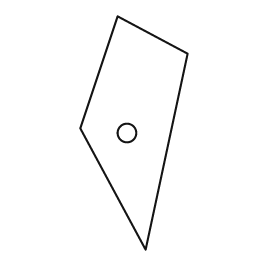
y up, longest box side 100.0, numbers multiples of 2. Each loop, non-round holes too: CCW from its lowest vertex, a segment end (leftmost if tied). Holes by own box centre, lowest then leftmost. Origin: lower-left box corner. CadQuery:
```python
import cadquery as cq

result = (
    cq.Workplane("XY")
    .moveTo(28.0, 0.0)
    .lineTo(46.0, 84.0)
    .lineTo(16.0, 100.0)
    .lineTo(0.0, 52.0)
    .close()
    .moveTo(20.0, 50.0)
    .circle(4.0)
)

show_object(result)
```